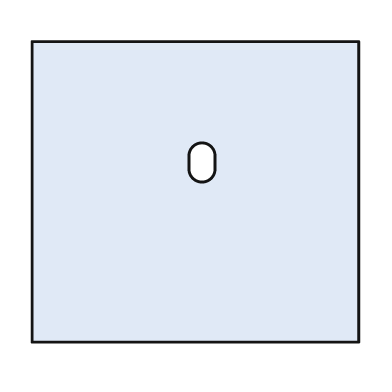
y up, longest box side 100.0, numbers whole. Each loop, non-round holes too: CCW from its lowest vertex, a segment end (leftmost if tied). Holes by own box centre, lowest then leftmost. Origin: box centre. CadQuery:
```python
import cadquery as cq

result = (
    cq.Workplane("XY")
    .moveTo(-50.0, -46.0)
    .lineTo(50.0, -46.0)
    .lineTo(50.0, 46.0)
    .lineTo(-50.0, 46.0)
    .close()
    .moveTo(-2.0, 7.0)
    .threePointArc((2.0, 3.0), (6.0, 7.0))
    .lineTo(6.0, 11.0)
    .threePointArc((2.0, 15.0), (-2.0, 11.0))
    .close()
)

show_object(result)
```